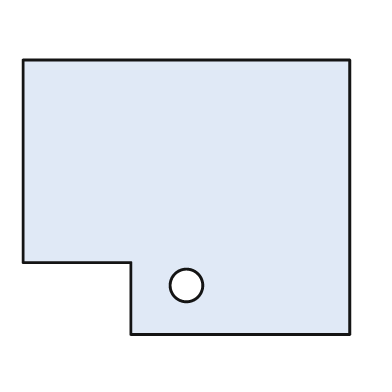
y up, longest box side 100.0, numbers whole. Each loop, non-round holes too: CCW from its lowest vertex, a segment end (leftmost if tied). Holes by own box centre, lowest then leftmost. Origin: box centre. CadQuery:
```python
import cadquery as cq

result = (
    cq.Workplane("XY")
    .moveTo(-17.0, -42.0)
    .lineTo(50.0, -42.0)
    .lineTo(50.0, 42.0)
    .lineTo(-50.0, 42.0)
    .lineTo(-50.0, -20.0)
    .lineTo(-17.0, -20.0)
    .close()
    .moveTo(0.0, -27.0)
    .circle(5.0)
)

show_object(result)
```